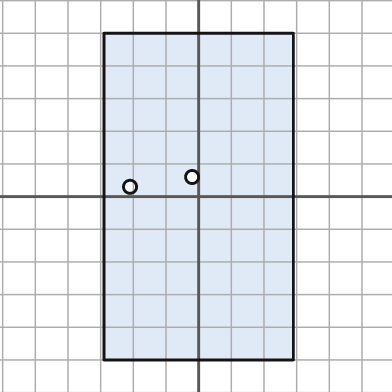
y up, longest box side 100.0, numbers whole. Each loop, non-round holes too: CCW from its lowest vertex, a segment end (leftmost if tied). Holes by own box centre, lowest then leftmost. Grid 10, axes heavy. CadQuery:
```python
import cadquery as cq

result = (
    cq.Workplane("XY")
    .moveTo(-29.0, -50.0)
    .lineTo(29.0, -50.0)
    .lineTo(29.0, 50.0)
    .lineTo(-29.0, 50.0)
    .close()
    .moveTo(-21.0, 3.0)
    .circle(2.0)
    .moveTo(-2.0, 6.0)
    .circle(2.0)
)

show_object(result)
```